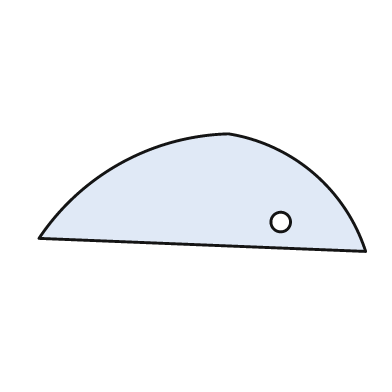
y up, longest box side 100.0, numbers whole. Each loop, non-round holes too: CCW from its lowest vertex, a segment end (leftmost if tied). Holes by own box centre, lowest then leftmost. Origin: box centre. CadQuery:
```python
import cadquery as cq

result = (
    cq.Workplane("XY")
    .moveTo(50.0, -18.0)
    .threePointArc((34.0, 6.0), (8.0, 18.0))
    .threePointArc((-25.0, 9.0), (-50.0, -14.0))
    .close()
    .moveTo(24.0, -9.0)
    .circle(3.0)
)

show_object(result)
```